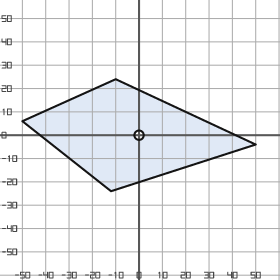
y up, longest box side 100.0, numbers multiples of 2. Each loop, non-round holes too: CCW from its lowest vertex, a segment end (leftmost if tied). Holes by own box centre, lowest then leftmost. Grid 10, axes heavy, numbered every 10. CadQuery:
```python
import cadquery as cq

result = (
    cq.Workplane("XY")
    .moveTo(-12.0, -24.0)
    .lineTo(50.0, -4.0)
    .lineTo(-10.0, 24.0)
    .lineTo(-50.0, 6.0)
    .close()
    .moveTo(0.0, 0.0)
    .circle(2.0)
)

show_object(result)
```